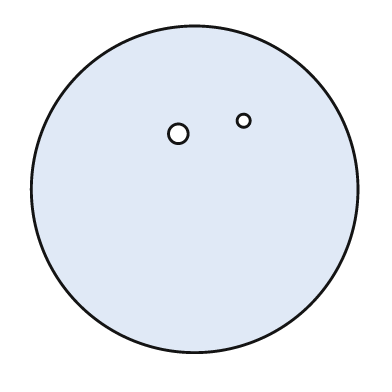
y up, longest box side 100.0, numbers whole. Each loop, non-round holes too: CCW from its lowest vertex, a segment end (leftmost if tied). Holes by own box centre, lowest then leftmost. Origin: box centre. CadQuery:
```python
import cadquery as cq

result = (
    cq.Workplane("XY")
    .moveTo(0.0, 0.0)
    .circle(50.0)
    .moveTo(-5.0, 17.0)
    .circle(3.0)
    .moveTo(15.0, 21.0)
    .circle(2.0)
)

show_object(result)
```